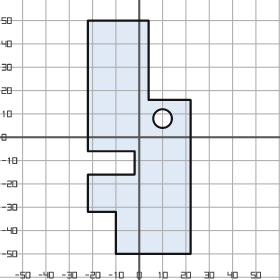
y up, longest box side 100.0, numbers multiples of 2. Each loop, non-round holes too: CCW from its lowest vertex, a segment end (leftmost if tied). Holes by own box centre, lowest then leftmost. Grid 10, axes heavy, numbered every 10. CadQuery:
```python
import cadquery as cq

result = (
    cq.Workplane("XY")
    .moveTo(-10.0, -50.0)
    .lineTo(22.0, -50.0)
    .lineTo(22.0, 16.0)
    .lineTo(4.0, 16.0)
    .lineTo(4.0, 50.0)
    .lineTo(-22.0, 50.0)
    .lineTo(-22.0, -6.0)
    .lineTo(-2.0, -6.0)
    .lineTo(-2.0, -16.0)
    .lineTo(-22.0, -16.0)
    .lineTo(-22.0, -32.0)
    .lineTo(-10.0, -32.0)
    .close()
    .moveTo(10.0, 8.0)
    .circle(4.0)
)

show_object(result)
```